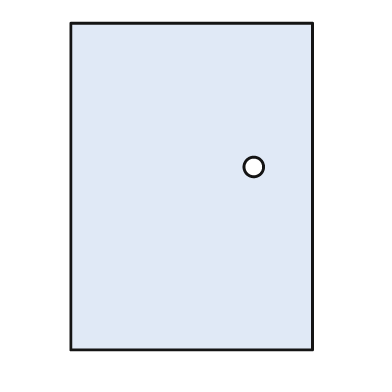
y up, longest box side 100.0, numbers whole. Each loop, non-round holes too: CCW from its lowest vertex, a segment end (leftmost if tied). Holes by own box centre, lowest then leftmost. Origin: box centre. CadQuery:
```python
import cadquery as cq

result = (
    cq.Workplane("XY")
    .moveTo(-37.0, -50.0)
    .lineTo(37.0, -50.0)
    .lineTo(37.0, 50.0)
    .lineTo(-37.0, 50.0)
    .close()
    .moveTo(19.0, 6.0)
    .circle(3.0)
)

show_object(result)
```